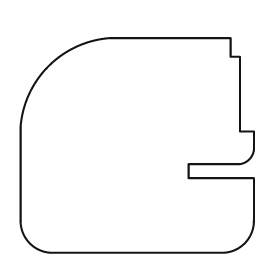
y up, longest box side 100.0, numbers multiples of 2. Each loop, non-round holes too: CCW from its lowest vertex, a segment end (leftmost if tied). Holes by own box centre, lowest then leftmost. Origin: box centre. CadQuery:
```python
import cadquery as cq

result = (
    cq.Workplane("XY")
    .moveTo(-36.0, -46.0)
    .lineTo(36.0, -46.0)
    .threePointArc((46.0, -42.0), (50.0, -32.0))
    .lineTo(50.0, -14.0)
    .lineTo(22.0, -14.0)
    .lineTo(22.0, -8.0)
    .lineTo(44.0, -8.0)
    .threePointArc((48.0, -6.0), (50.0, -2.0))
    .lineTo(50.0, 6.0)
    .lineTo(44.0, 6.0)
    .lineTo(44.0, 38.0)
    .lineTo(40.0, 38.0)
    .lineTo(40.0, 46.0)
    .lineTo(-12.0, 46.0)
    .threePointArc((-38.0, 34.0), (-50.0, 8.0))
    .lineTo(-50.0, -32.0)
    .threePointArc((-46.0, -42.0), (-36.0, -46.0))
    .close()
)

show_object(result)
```